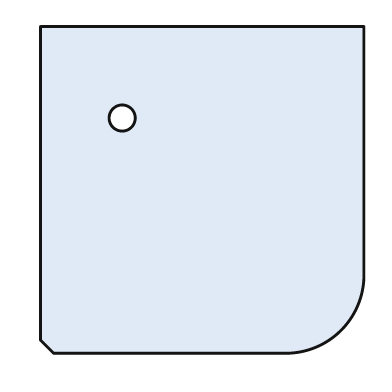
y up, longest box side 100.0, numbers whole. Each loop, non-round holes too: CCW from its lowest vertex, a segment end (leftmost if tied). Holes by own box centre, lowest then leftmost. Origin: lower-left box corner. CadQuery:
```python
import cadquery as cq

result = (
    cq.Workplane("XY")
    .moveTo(4.0, 0.0)
    .lineTo(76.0, 0.0)
    .threePointArc((92.0, 7.0), (99.0, 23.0))
    .lineTo(99.0, 100.0)
    .lineTo(0.0, 100.0)
    .lineTo(0.0, 4.0)
    .close()
    .moveTo(25.0, 72.0)
    .circle(4.0)
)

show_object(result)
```